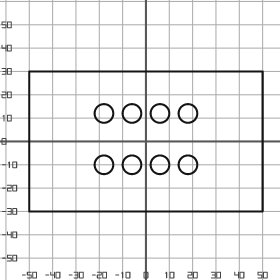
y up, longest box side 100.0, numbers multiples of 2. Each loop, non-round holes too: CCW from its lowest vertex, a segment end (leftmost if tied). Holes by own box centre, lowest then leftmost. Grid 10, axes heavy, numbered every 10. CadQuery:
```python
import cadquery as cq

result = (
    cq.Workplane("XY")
    .moveTo(-50.0, -30.0)
    .lineTo(50.0, -30.0)
    .lineTo(50.0, 30.0)
    .lineTo(-50.0, 30.0)
    .close()
    .moveTo(-18.0, -10.0)
    .circle(4.0)
    .moveTo(-6.0, -10.0)
    .circle(4.0)
    .moveTo(6.0, -10.0)
    .circle(4.0)
    .moveTo(18.0, -10.0)
    .circle(4.0)
    .moveTo(-18.0, 12.0)
    .circle(4.0)
    .moveTo(-6.0, 12.0)
    .circle(4.0)
    .moveTo(6.0, 12.0)
    .circle(4.0)
    .moveTo(18.0, 12.0)
    .circle(4.0)
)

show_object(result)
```